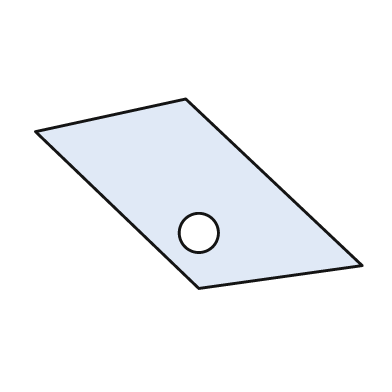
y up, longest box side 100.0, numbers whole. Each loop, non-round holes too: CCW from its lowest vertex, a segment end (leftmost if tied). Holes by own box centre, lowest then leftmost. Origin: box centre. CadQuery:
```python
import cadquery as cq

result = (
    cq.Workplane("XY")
    .moveTo(0.0, -29.0)
    .lineTo(50.0, -22.0)
    .lineTo(-4.0, 29.0)
    .lineTo(-50.0, 19.0)
    .close()
    .moveTo(0.0, -12.0)
    .circle(6.0)
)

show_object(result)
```